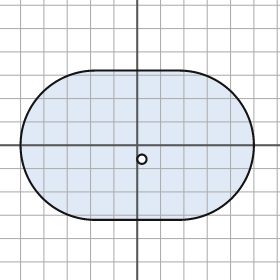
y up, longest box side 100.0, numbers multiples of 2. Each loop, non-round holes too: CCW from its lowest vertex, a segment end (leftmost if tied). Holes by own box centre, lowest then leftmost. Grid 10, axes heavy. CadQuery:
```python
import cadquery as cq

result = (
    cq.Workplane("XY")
    .moveTo(-18.0, -32.0)
    .lineTo(18.0, -32.0)
    .threePointArc((50.0, 0.0), (18.0, 32.0))
    .lineTo(-18.0, 32.0)
    .threePointArc((-50.0, 0.0), (-18.0, -32.0))
    .close()
    .moveTo(2.0, -6.0)
    .circle(2.0)
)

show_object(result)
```